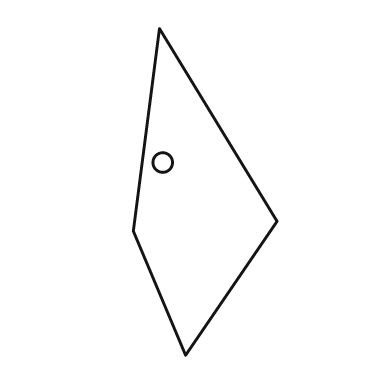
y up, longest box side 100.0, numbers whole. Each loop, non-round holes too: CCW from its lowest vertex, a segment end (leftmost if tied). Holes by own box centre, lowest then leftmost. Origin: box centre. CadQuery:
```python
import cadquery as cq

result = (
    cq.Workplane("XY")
    .moveTo(-6.0, -50.0)
    .lineTo(22.0, -9.0)
    .lineTo(-14.0, 50.0)
    .lineTo(-22.0, -12.0)
    .close()
    .moveTo(-13.0, 9.0)
    .circle(3.0)
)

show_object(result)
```